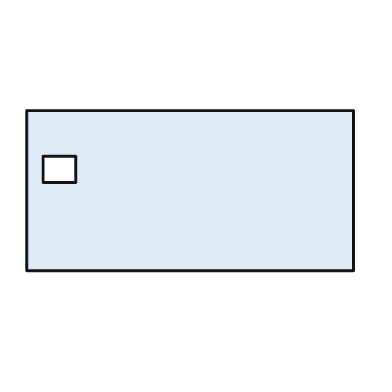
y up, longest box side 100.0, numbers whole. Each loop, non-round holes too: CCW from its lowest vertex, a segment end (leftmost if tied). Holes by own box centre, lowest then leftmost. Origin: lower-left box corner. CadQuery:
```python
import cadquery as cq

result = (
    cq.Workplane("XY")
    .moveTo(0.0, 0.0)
    .lineTo(100.0, 0.0)
    .lineTo(100.0, 49.0)
    .lineTo(0.0, 49.0)
    .close()
    .moveTo(5.0, 27.0)
    .lineTo(15.0, 27.0)
    .lineTo(15.0, 35.0)
    .lineTo(5.0, 35.0)
    .close()
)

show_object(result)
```